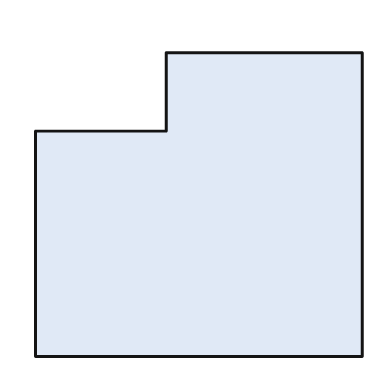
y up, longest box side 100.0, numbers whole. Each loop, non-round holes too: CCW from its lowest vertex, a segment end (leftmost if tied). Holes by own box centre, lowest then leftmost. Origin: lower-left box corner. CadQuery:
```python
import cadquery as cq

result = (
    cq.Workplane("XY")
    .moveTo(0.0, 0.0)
    .lineTo(100.0, 0.0)
    .lineTo(100.0, 93.0)
    .lineTo(40.0, 93.0)
    .lineTo(40.0, 69.0)
    .lineTo(0.0, 69.0)
    .close()
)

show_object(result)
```